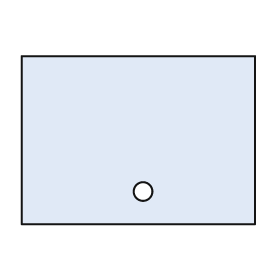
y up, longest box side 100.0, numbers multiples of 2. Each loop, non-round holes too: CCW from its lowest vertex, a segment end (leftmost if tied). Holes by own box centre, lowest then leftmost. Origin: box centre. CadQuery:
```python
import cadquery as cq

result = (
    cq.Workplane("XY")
    .moveTo(-50.0, -36.0)
    .lineTo(50.0, -36.0)
    .lineTo(50.0, 36.0)
    .lineTo(-50.0, 36.0)
    .close()
    .moveTo(2.0, -22.0)
    .circle(4.0)
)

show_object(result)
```